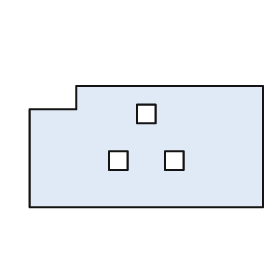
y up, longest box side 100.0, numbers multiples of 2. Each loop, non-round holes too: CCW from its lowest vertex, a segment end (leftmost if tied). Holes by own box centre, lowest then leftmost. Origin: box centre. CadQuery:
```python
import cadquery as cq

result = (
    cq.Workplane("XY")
    .moveTo(-50.0, -26.0)
    .lineTo(50.0, -26.0)
    .lineTo(50.0, 26.0)
    .lineTo(-30.0, 26.0)
    .lineTo(-30.0, 16.0)
    .lineTo(-50.0, 16.0)
    .close()
    .moveTo(-16.0, -10.0)
    .lineTo(-8.0, -10.0)
    .lineTo(-8.0, -2.0)
    .lineTo(-16.0, -2.0)
    .close()
    .moveTo(8.0, -10.0)
    .lineTo(16.0, -10.0)
    .lineTo(16.0, -2.0)
    .lineTo(8.0, -2.0)
    .close()
    .moveTo(-4.0, 10.0)
    .lineTo(4.0, 10.0)
    .lineTo(4.0, 18.0)
    .lineTo(-4.0, 18.0)
    .close()
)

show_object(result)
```